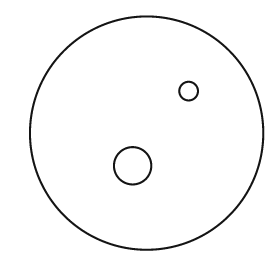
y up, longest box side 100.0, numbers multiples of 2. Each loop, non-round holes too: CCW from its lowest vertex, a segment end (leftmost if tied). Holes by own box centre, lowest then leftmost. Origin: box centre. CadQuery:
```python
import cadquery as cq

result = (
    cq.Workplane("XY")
    .moveTo(0.0, 0.0)
    .circle(50.0)
    .moveTo(-6.0, -14.0)
    .circle(8.0)
    .moveTo(18.0, 18.0)
    .circle(4.0)
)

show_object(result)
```